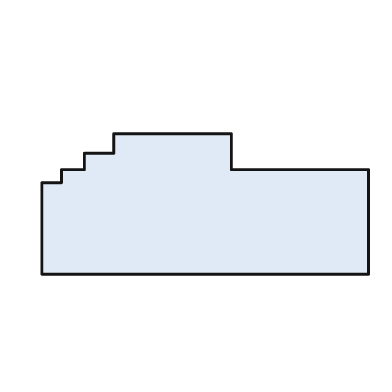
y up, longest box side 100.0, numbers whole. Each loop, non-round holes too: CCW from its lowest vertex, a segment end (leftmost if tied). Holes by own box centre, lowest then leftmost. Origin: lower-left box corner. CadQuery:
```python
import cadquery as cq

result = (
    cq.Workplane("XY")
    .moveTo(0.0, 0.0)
    .lineTo(100.0, 0.0)
    .lineTo(100.0, 32.0)
    .lineTo(58.0, 32.0)
    .lineTo(58.0, 43.0)
    .lineTo(22.0, 43.0)
    .lineTo(22.0, 37.0)
    .lineTo(13.0, 37.0)
    .lineTo(13.0, 32.0)
    .lineTo(6.0, 32.0)
    .lineTo(6.0, 28.0)
    .lineTo(0.0, 28.0)
    .close()
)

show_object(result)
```